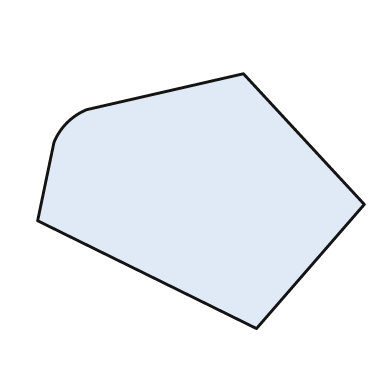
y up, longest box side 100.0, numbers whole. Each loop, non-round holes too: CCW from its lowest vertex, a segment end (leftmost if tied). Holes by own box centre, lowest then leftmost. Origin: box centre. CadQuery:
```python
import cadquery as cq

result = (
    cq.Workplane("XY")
    .moveTo(17.0, -39.0)
    .lineTo(50.0, -1.0)
    .lineTo(13.0, 39.0)
    .lineTo(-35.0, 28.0)
    .threePointArc((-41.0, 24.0), (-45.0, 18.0))
    .lineTo(-50.0, -6.0)
    .close()
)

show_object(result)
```